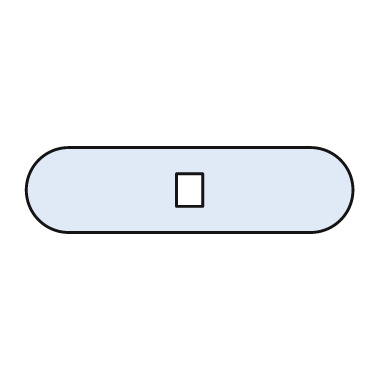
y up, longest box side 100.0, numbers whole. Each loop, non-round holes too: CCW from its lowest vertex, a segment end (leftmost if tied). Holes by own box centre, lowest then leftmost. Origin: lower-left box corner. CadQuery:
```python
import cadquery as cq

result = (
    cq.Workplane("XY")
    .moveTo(13.0, 0.0)
    .lineTo(87.0, 0.0)
    .threePointArc((100.0, 13.0), (87.0, 26.0))
    .lineTo(13.0, 26.0)
    .threePointArc((0.0, 13.0), (13.0, 0.0))
    .close()
    .moveTo(46.0, 8.0)
    .lineTo(54.0, 8.0)
    .lineTo(54.0, 18.0)
    .lineTo(46.0, 18.0)
    .close()
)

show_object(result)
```